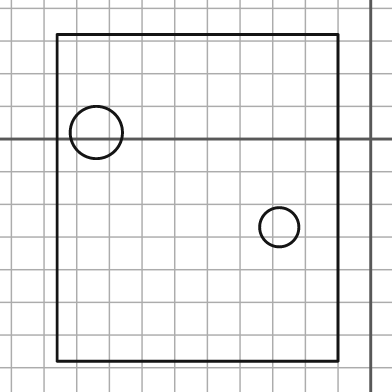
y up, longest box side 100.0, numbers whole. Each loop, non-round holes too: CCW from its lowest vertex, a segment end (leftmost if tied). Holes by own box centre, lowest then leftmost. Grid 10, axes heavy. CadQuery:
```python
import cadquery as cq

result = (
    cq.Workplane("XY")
    .moveTo(-96.0, -68.0)
    .lineTo(-10.0, -68.0)
    .lineTo(-10.0, 32.0)
    .lineTo(-96.0, 32.0)
    .close()
    .moveTo(-28.0, -27.0)
    .circle(6.0)
    .moveTo(-84.0, 2.0)
    .circle(8.0)
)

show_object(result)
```